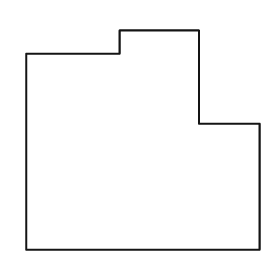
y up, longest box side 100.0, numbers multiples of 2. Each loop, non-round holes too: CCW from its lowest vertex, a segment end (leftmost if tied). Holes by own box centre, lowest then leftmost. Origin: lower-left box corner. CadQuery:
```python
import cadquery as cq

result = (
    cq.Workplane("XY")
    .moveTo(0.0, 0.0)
    .lineTo(100.0, 0.0)
    .lineTo(100.0, 54.0)
    .lineTo(74.0, 54.0)
    .lineTo(74.0, 94.0)
    .lineTo(40.0, 94.0)
    .lineTo(40.0, 84.0)
    .lineTo(0.0, 84.0)
    .close()
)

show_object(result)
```